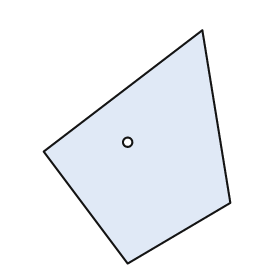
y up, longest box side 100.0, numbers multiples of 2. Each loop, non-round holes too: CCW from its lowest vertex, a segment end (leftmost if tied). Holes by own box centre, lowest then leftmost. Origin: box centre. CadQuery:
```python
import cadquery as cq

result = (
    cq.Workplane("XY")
    .moveTo(-4.0, -50.0)
    .lineTo(40.0, -24.0)
    .lineTo(28.0, 50.0)
    .lineTo(-40.0, -2.0)
    .close()
    .moveTo(-4.0, 2.0)
    .circle(2.0)
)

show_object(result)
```